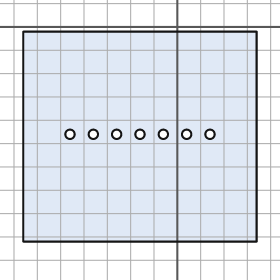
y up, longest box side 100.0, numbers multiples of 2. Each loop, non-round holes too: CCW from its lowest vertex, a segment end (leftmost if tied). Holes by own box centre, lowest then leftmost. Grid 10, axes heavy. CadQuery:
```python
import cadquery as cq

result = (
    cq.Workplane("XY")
    .moveTo(-66.0, -92.0)
    .lineTo(34.0, -92.0)
    .lineTo(34.0, -2.0)
    .lineTo(-66.0, -2.0)
    .close()
    .moveTo(-46.0, -46.0)
    .circle(2.0)
    .moveTo(-36.0, -46.0)
    .circle(2.0)
    .moveTo(-26.0, -46.0)
    .circle(2.0)
    .moveTo(-16.0, -46.0)
    .circle(2.0)
    .moveTo(-6.0, -46.0)
    .circle(2.0)
    .moveTo(4.0, -46.0)
    .circle(2.0)
    .moveTo(14.0, -46.0)
    .circle(2.0)
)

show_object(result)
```